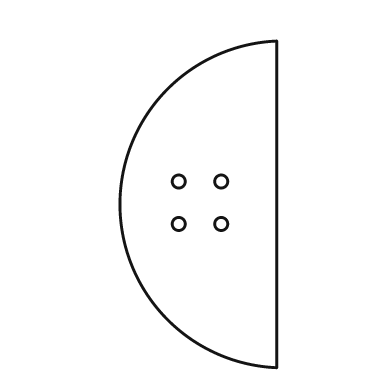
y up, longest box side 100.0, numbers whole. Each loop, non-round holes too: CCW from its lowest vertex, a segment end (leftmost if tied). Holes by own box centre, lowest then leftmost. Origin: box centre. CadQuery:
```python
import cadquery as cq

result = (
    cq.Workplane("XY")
    .moveTo(24.0, -50.0)
    .lineTo(24.0, 50.0)
    .threePointArc((-24.0, 0.0), (24.0, -50.0))
    .close()
    .moveTo(-6.0, -6.0)
    .circle(2.0)
    .moveTo(7.0, -6.0)
    .circle(2.0)
    .moveTo(-6.0, 7.0)
    .circle(2.0)
    .moveTo(7.0, 7.0)
    .circle(2.0)
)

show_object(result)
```